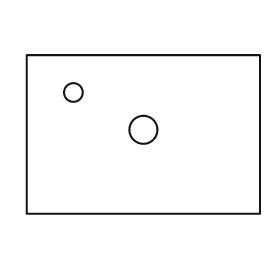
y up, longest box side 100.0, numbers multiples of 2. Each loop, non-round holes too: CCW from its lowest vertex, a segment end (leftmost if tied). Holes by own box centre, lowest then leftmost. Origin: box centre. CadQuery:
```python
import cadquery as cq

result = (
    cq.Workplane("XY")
    .moveTo(-50.0, -34.0)
    .lineTo(50.0, -34.0)
    .lineTo(50.0, 34.0)
    .lineTo(-50.0, 34.0)
    .close()
    .moveTo(0.0, 2.0)
    .circle(6.0)
    .moveTo(-30.0, 18.0)
    .circle(4.0)
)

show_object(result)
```